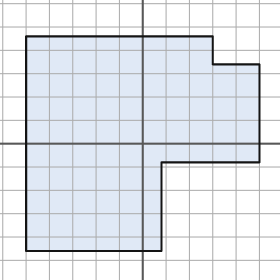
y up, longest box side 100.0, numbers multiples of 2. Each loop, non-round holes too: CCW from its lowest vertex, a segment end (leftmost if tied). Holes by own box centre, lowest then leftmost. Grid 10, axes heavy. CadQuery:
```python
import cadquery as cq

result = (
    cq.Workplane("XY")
    .moveTo(-50.0, -46.0)
    .lineTo(8.0, -46.0)
    .lineTo(8.0, -8.0)
    .lineTo(50.0, -8.0)
    .lineTo(50.0, 34.0)
    .lineTo(30.0, 34.0)
    .lineTo(30.0, 46.0)
    .lineTo(-50.0, 46.0)
    .close()
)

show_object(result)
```